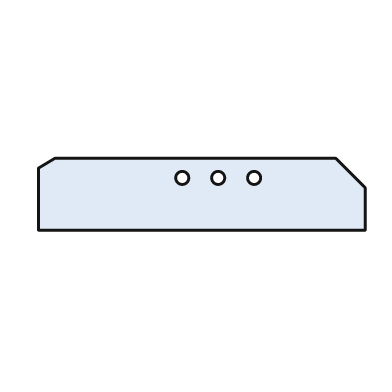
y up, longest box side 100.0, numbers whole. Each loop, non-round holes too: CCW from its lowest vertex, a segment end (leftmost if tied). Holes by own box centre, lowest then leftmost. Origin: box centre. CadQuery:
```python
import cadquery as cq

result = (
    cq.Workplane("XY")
    .moveTo(-50.0, -11.0)
    .lineTo(50.0, -11.0)
    .lineTo(50.0, 2.0)
    .lineTo(41.0, 11.0)
    .lineTo(-45.0, 11.0)
    .lineTo(-50.0, 8.0)
    .close()
    .moveTo(-6.0, 5.0)
    .circle(2.0)
    .moveTo(5.0, 5.0)
    .circle(2.0)
    .moveTo(16.0, 5.0)
    .circle(2.0)
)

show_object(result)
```